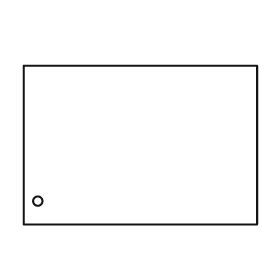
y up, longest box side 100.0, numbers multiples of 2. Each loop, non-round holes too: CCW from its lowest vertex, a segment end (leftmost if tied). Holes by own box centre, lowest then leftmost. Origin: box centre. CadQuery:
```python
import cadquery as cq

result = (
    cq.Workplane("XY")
    .moveTo(-50.0, -34.0)
    .lineTo(50.0, -34.0)
    .lineTo(50.0, 34.0)
    .lineTo(-50.0, 34.0)
    .close()
    .moveTo(-44.0, -24.0)
    .circle(2.0)
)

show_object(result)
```